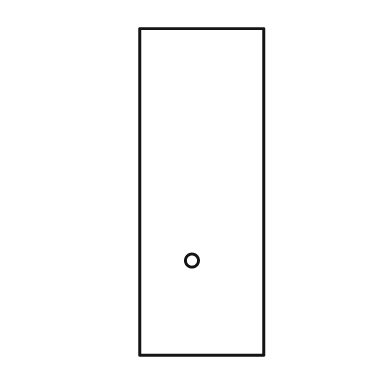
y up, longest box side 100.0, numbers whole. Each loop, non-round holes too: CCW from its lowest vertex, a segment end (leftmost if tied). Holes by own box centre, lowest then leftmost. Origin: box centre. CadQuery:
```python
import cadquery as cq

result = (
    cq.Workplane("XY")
    .moveTo(-19.0, -50.0)
    .lineTo(19.0, -50.0)
    .lineTo(19.0, 50.0)
    .lineTo(-19.0, 50.0)
    .close()
    .moveTo(-3.0, -21.0)
    .circle(2.0)
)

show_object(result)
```